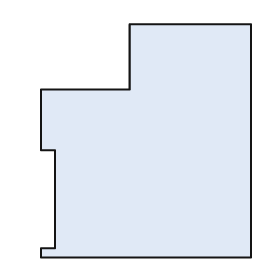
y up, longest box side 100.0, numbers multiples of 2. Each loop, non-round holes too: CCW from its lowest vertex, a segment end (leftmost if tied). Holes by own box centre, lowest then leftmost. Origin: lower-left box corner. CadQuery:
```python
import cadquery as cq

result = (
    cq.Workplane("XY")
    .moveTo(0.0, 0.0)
    .lineTo(90.0, 0.0)
    .lineTo(90.0, 100.0)
    .lineTo(38.0, 100.0)
    .lineTo(38.0, 72.0)
    .lineTo(0.0, 72.0)
    .lineTo(0.0, 46.0)
    .lineTo(6.0, 46.0)
    .lineTo(6.0, 4.0)
    .lineTo(0.0, 4.0)
    .close()
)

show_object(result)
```